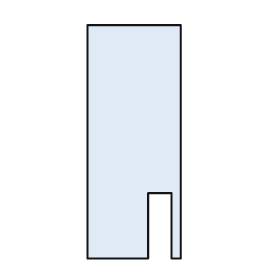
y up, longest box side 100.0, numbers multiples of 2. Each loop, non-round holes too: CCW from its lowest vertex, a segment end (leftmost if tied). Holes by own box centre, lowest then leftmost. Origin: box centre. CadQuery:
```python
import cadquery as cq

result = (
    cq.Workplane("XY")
    .moveTo(-20.0, -50.0)
    .lineTo(6.0, -50.0)
    .lineTo(6.0, -22.0)
    .lineTo(16.0, -22.0)
    .lineTo(16.0, -50.0)
    .lineTo(20.0, -50.0)
    .lineTo(20.0, 50.0)
    .lineTo(-20.0, 50.0)
    .close()
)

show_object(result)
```